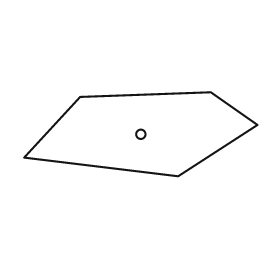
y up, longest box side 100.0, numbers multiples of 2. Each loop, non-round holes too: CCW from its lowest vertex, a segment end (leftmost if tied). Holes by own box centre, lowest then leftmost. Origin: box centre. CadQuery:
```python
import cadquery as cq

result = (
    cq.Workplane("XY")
    .moveTo(16.0, -18.0)
    .lineTo(50.0, 4.0)
    .lineTo(30.0, 18.0)
    .lineTo(-26.0, 16.0)
    .lineTo(-50.0, -10.0)
    .close()
    .moveTo(0.0, 0.0)
    .circle(2.0)
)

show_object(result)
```